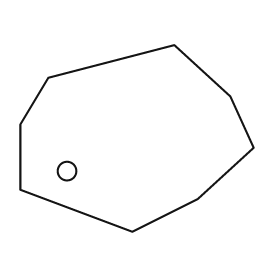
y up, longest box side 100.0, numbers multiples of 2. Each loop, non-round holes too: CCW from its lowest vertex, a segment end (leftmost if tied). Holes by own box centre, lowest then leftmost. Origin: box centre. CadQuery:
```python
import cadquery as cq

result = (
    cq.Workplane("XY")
    .moveTo(-2.0, -40.0)
    .lineTo(26.0, -26.0)
    .lineTo(50.0, -4.0)
    .lineTo(40.0, 18.0)
    .lineTo(16.0, 40.0)
    .lineTo(-38.0, 26.0)
    .lineTo(-50.0, 6.0)
    .lineTo(-50.0, -22.0)
    .close()
    .moveTo(-30.0, -14.0)
    .circle(4.0)
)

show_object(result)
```